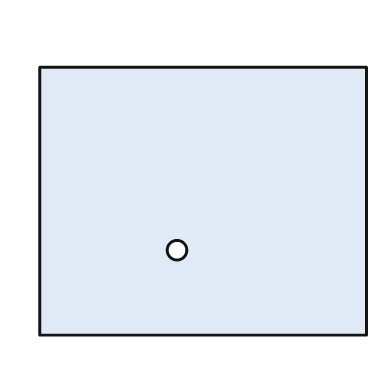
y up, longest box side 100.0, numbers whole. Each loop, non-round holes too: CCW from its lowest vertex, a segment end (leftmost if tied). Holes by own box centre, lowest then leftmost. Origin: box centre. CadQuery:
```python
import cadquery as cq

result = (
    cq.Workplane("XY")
    .moveTo(-50.0, -41.0)
    .lineTo(50.0, -41.0)
    .lineTo(50.0, 41.0)
    .lineTo(-50.0, 41.0)
    .close()
    .moveTo(-8.0, -15.0)
    .circle(3.0)
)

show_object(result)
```